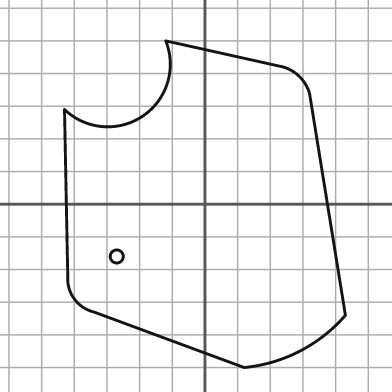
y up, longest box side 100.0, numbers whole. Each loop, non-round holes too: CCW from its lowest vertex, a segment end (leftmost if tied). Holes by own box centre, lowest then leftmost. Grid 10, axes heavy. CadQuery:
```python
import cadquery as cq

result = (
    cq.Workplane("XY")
    .moveTo(12.0, -50.0)
    .threePointArc((29.0, -45.0), (43.0, -34.0))
    .lineTo(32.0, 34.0)
    .threePointArc((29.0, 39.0), (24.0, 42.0))
    .lineTo(-12.0, 50.0)
    .threePointArc((-19.0, 27.0), (-43.0, 29.0))
    .lineTo(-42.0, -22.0)
    .threePointArc((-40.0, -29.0), (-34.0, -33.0))
    .close()
    .moveTo(-27.0, -16.0)
    .circle(2.0)
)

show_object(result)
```